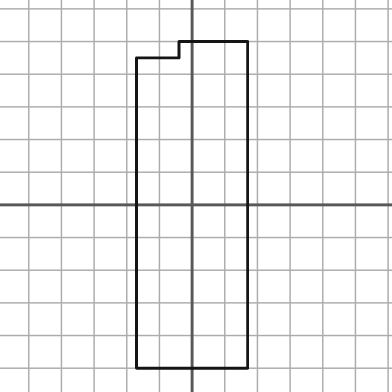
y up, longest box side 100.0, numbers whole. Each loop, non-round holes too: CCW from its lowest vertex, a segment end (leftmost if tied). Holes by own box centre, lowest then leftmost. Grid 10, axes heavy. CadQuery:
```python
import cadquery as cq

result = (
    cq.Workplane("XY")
    .moveTo(-17.0, -50.0)
    .lineTo(17.0, -50.0)
    .lineTo(17.0, 50.0)
    .lineTo(-4.0, 50.0)
    .lineTo(-4.0, 45.0)
    .lineTo(-17.0, 45.0)
    .close()
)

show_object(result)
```